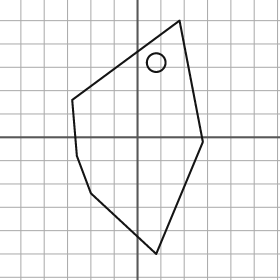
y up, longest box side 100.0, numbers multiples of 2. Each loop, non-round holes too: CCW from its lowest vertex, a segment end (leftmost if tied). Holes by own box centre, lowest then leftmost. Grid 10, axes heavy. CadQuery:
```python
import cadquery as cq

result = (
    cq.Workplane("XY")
    .moveTo(8.0, -50.0)
    .lineTo(28.0, -2.0)
    .lineTo(18.0, 50.0)
    .lineTo(-28.0, 16.0)
    .lineTo(-26.0, -8.0)
    .lineTo(-20.0, -24.0)
    .close()
    .moveTo(8.0, 32.0)
    .circle(4.0)
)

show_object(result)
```